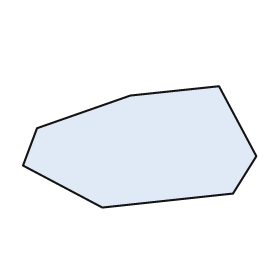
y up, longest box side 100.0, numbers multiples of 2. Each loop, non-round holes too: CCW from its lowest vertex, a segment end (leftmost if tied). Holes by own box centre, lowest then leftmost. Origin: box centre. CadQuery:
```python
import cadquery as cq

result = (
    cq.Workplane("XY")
    .moveTo(-16.0, -26.0)
    .lineTo(40.0, -20.0)
    .lineTo(50.0, -4.0)
    .lineTo(34.0, 26.0)
    .lineTo(-4.0, 22.0)
    .lineTo(-44.0, 8.0)
    .lineTo(-50.0, -8.0)
    .close()
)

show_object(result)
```